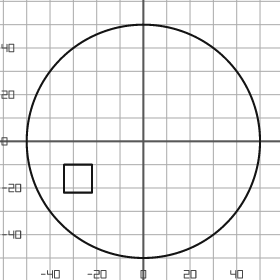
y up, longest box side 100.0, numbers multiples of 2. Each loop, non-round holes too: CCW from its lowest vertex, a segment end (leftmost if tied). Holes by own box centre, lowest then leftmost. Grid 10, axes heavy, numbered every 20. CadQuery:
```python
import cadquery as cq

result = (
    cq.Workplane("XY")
    .moveTo(0.0, 0.0)
    .circle(50.0)
    .moveTo(-34.0, -22.0)
    .lineTo(-22.0, -22.0)
    .lineTo(-22.0, -10.0)
    .lineTo(-34.0, -10.0)
    .close()
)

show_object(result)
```